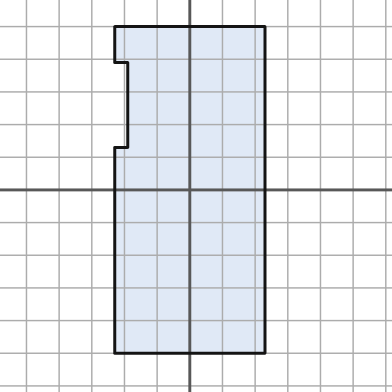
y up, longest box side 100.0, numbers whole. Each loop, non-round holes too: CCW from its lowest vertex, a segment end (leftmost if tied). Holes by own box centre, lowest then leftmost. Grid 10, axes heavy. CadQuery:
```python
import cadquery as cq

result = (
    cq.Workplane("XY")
    .moveTo(-23.0, -50.0)
    .lineTo(23.0, -50.0)
    .lineTo(23.0, 50.0)
    .lineTo(-23.0, 50.0)
    .lineTo(-23.0, 39.0)
    .lineTo(-19.0, 39.0)
    .lineTo(-19.0, 13.0)
    .lineTo(-23.0, 13.0)
    .close()
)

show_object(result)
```